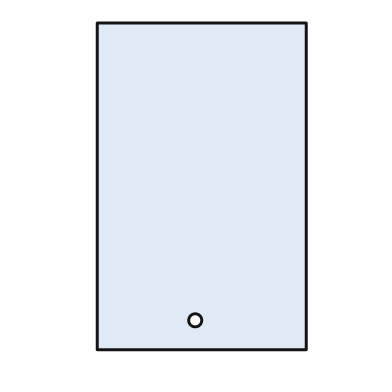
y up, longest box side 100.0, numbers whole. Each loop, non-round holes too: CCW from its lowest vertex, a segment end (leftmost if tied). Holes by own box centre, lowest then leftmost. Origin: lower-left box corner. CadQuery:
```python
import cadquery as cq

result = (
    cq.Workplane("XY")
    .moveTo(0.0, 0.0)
    .lineTo(64.0, 0.0)
    .lineTo(64.0, 100.0)
    .lineTo(0.0, 100.0)
    .close()
    .moveTo(30.0, 9.0)
    .circle(2.0)
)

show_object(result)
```